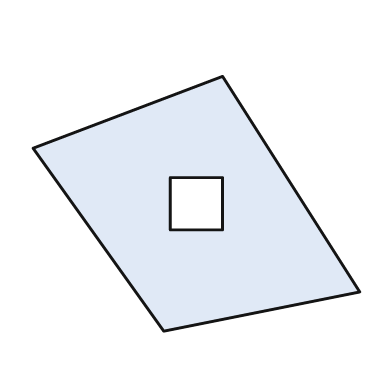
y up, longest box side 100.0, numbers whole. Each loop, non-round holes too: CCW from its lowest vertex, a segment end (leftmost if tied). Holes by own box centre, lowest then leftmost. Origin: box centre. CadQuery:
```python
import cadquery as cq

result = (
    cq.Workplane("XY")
    .moveTo(-10.0, -39.0)
    .lineTo(50.0, -27.0)
    .lineTo(8.0, 39.0)
    .lineTo(-50.0, 17.0)
    .close()
    .moveTo(-8.0, -8.0)
    .lineTo(8.0, -8.0)
    .lineTo(8.0, 8.0)
    .lineTo(-8.0, 8.0)
    .close()
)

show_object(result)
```